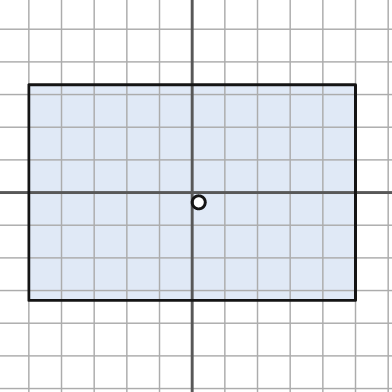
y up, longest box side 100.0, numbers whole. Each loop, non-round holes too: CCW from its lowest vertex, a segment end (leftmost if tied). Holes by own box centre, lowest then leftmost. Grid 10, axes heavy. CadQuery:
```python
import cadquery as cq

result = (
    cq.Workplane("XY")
    .moveTo(-50.0, -33.0)
    .lineTo(50.0, -33.0)
    .lineTo(50.0, 33.0)
    .lineTo(-50.0, 33.0)
    .close()
    .moveTo(2.0, -3.0)
    .circle(2.0)
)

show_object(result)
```